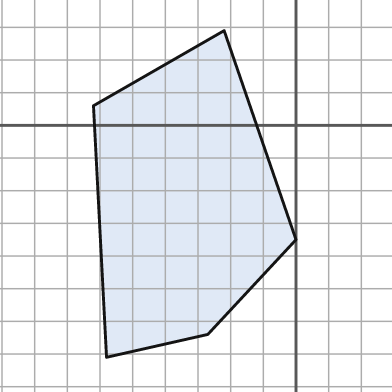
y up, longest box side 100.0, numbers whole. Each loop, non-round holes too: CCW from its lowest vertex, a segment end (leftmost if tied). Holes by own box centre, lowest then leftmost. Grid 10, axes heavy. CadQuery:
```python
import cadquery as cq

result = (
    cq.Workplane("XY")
    .moveTo(-58.0, -71.0)
    .lineTo(-27.0, -64.0)
    .lineTo(0.0, -35.0)
    .lineTo(-22.0, 29.0)
    .lineTo(-62.0, 6.0)
    .close()
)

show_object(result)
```